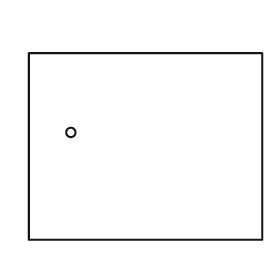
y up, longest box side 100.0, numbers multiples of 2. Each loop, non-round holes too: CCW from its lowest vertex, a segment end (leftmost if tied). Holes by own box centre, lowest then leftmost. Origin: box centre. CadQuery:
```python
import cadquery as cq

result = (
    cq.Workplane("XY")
    .moveTo(-50.0, -40.0)
    .lineTo(50.0, -40.0)
    .lineTo(50.0, 40.0)
    .lineTo(-50.0, 40.0)
    .close()
    .moveTo(-32.0, 6.0)
    .circle(2.0)
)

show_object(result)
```